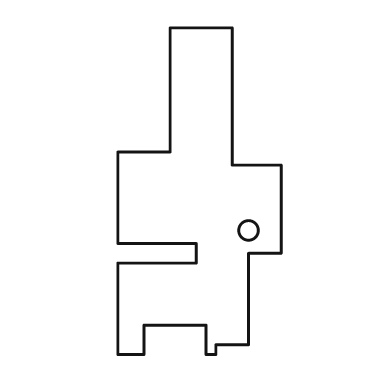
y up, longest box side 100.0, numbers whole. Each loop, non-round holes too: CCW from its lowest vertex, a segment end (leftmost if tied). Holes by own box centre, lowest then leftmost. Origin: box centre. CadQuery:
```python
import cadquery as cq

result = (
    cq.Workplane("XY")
    .moveTo(-25.0, -50.0)
    .lineTo(-17.0, -50.0)
    .lineTo(-17.0, -41.0)
    .lineTo(2.0, -41.0)
    .lineTo(2.0, -50.0)
    .lineTo(5.0, -50.0)
    .lineTo(5.0, -47.0)
    .lineTo(15.0, -47.0)
    .lineTo(15.0, -19.0)
    .lineTo(25.0, -19.0)
    .lineTo(25.0, 8.0)
    .lineTo(10.0, 8.0)
    .lineTo(10.0, 50.0)
    .lineTo(-9.0, 50.0)
    .lineTo(-9.0, 12.0)
    .lineTo(-25.0, 12.0)
    .lineTo(-25.0, -16.0)
    .lineTo(-1.0, -16.0)
    .lineTo(-1.0, -22.0)
    .lineTo(-25.0, -22.0)
    .close()
    .moveTo(15.0, -12.0)
    .circle(3.0)
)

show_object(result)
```